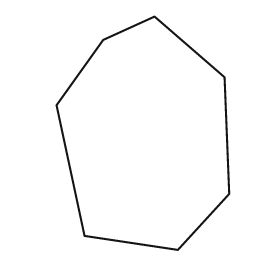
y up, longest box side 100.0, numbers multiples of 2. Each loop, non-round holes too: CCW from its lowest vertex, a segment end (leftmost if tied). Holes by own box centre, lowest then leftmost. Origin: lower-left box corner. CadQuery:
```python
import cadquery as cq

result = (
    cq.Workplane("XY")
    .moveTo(52.0, 0.0)
    .lineTo(74.0, 24.0)
    .lineTo(72.0, 74.0)
    .lineTo(42.0, 100.0)
    .lineTo(20.0, 90.0)
    .lineTo(0.0, 62.0)
    .lineTo(12.0, 6.0)
    .close()
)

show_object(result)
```